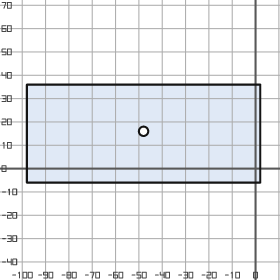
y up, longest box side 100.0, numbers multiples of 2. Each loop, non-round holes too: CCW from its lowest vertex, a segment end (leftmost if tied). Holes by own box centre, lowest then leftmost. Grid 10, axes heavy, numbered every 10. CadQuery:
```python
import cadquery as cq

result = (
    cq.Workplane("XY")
    .moveTo(-98.0, -6.0)
    .lineTo(2.0, -6.0)
    .lineTo(2.0, 36.0)
    .lineTo(-98.0, 36.0)
    .close()
    .moveTo(-48.0, 16.0)
    .circle(2.0)
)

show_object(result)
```